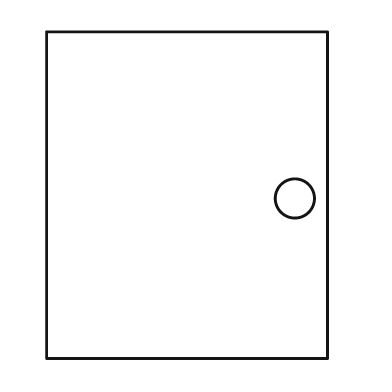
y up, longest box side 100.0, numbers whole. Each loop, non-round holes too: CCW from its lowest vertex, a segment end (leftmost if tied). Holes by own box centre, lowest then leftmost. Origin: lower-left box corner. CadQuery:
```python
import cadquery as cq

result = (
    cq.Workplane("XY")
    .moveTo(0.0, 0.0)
    .lineTo(86.0, 0.0)
    .lineTo(86.0, 100.0)
    .lineTo(0.0, 100.0)
    .close()
    .moveTo(76.0, 49.0)
    .circle(6.0)
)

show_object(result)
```